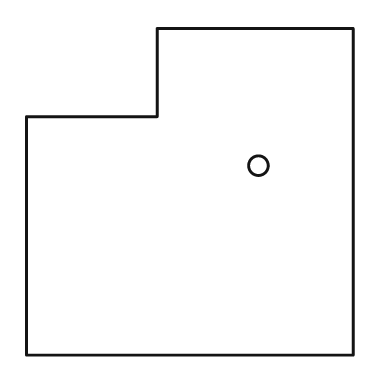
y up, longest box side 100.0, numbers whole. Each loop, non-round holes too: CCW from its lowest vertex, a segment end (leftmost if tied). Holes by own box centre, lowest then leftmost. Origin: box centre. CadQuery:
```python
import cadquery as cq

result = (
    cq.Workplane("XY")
    .moveTo(-50.0, -50.0)
    .lineTo(50.0, -50.0)
    .lineTo(50.0, 50.0)
    .lineTo(-10.0, 50.0)
    .lineTo(-10.0, 23.0)
    .lineTo(-50.0, 23.0)
    .close()
    .moveTo(21.0, 8.0)
    .circle(3.0)
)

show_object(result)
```